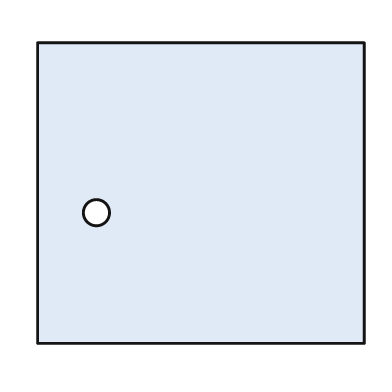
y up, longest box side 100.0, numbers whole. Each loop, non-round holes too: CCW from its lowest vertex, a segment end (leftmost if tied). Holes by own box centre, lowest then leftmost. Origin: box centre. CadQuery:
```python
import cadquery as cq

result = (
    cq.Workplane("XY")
    .moveTo(-50.0, -46.0)
    .lineTo(50.0, -46.0)
    .lineTo(50.0, 46.0)
    .lineTo(-50.0, 46.0)
    .close()
    .moveTo(-32.0, -6.0)
    .circle(4.0)
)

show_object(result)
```